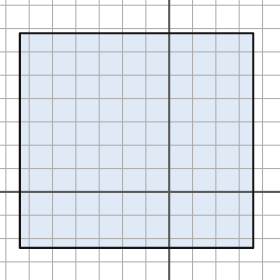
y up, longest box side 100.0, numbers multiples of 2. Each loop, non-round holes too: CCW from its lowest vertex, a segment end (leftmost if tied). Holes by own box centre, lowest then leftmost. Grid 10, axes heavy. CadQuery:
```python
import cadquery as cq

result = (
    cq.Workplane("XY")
    .moveTo(-64.0, -24.0)
    .lineTo(36.0, -24.0)
    .lineTo(36.0, 68.0)
    .lineTo(-64.0, 68.0)
    .close()
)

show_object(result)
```